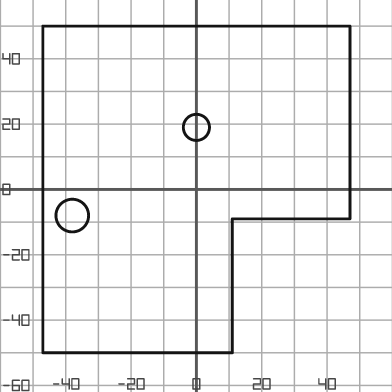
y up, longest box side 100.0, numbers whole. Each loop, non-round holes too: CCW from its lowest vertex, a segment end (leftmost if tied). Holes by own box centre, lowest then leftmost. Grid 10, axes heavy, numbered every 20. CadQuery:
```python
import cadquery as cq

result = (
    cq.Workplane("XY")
    .moveTo(-47.0, -50.0)
    .lineTo(11.0, -50.0)
    .lineTo(11.0, -9.0)
    .lineTo(47.0, -9.0)
    .lineTo(47.0, 50.0)
    .lineTo(-47.0, 50.0)
    .close()
    .moveTo(-38.0, -8.0)
    .circle(5.0)
    .moveTo(0.0, 19.0)
    .circle(4.0)
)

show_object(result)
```